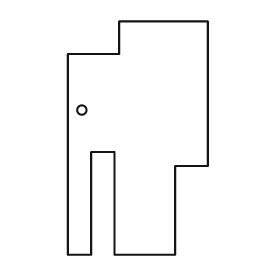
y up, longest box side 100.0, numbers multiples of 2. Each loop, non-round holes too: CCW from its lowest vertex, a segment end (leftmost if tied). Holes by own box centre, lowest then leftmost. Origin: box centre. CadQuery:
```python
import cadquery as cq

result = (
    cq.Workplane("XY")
    .moveTo(-30.0, -50.0)
    .lineTo(-20.0, -50.0)
    .lineTo(-20.0, -6.0)
    .lineTo(-10.0, -6.0)
    .lineTo(-10.0, -50.0)
    .lineTo(16.0, -50.0)
    .lineTo(16.0, -12.0)
    .lineTo(30.0, -12.0)
    .lineTo(30.0, 50.0)
    .lineTo(-8.0, 50.0)
    .lineTo(-8.0, 36.0)
    .lineTo(-30.0, 36.0)
    .close()
    .moveTo(-24.0, 12.0)
    .circle(2.0)
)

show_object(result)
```